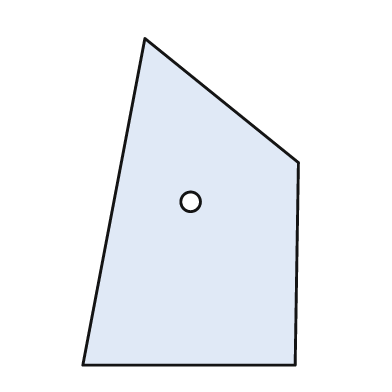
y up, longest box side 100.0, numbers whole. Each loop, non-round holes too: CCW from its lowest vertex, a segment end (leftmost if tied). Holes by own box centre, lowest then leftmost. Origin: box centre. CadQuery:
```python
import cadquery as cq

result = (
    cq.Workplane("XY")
    .moveTo(-33.0, -50.0)
    .lineTo(32.0, -50.0)
    .lineTo(33.0, 12.0)
    .lineTo(-14.0, 50.0)
    .close()
    .moveTo(0.0, 0.0)
    .circle(3.0)
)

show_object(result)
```